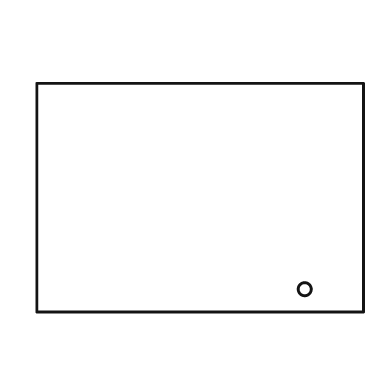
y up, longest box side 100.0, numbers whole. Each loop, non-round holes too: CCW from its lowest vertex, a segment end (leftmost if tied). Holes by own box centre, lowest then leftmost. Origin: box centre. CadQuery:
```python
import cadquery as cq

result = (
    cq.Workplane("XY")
    .moveTo(-50.0, -35.0)
    .lineTo(50.0, -35.0)
    .lineTo(50.0, 35.0)
    .lineTo(-50.0, 35.0)
    .close()
    .moveTo(32.0, -28.0)
    .circle(2.0)
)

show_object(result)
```